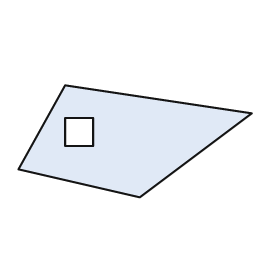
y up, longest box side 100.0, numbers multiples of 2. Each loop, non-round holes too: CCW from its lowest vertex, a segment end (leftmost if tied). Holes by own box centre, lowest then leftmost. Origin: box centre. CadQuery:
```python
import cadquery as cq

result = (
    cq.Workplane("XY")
    .moveTo(2.0, -24.0)
    .lineTo(50.0, 12.0)
    .lineTo(-30.0, 24.0)
    .lineTo(-50.0, -12.0)
    .close()
    .moveTo(-30.0, -2.0)
    .lineTo(-18.0, -2.0)
    .lineTo(-18.0, 10.0)
    .lineTo(-30.0, 10.0)
    .close()
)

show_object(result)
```